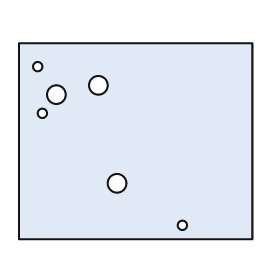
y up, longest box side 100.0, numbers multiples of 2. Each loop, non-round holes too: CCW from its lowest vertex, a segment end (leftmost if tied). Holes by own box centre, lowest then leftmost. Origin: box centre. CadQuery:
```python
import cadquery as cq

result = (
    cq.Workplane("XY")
    .moveTo(-50.0, -42.0)
    .lineTo(50.0, -42.0)
    .lineTo(50.0, 42.0)
    .lineTo(-50.0, 42.0)
    .close()
    .moveTo(20.0, -36.0)
    .circle(2.0)
    .moveTo(-8.0, -18.0)
    .circle(4.0)
    .moveTo(-40.0, 12.0)
    .circle(2.0)
    .moveTo(-34.0, 20.0)
    .circle(4.0)
    .moveTo(-16.0, 24.0)
    .circle(4.0)
    .moveTo(-42.0, 32.0)
    .circle(2.0)
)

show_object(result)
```